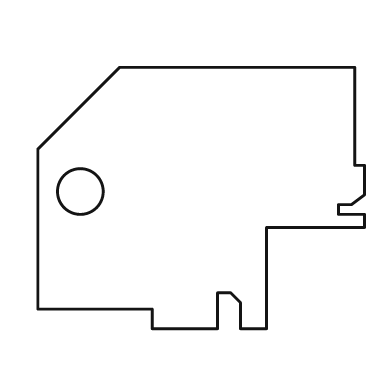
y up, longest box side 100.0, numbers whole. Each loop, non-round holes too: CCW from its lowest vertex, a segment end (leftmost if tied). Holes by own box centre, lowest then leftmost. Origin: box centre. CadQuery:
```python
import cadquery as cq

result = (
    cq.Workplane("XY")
    .moveTo(-15.0, -40.0)
    .lineTo(5.0, -40.0)
    .lineTo(5.0, -29.0)
    .lineTo(9.0, -29.0)
    .lineTo(12.0, -32.0)
    .lineTo(12.0, -40.0)
    .lineTo(20.0, -40.0)
    .lineTo(20.0, -9.0)
    .lineTo(50.0, -9.0)
    .lineTo(50.0, -5.0)
    .lineTo(42.0, -5.0)
    .lineTo(42.0, -2.0)
    .lineTo(46.0, -2.0)
    .lineTo(50.0, 1.0)
    .lineTo(50.0, 10.0)
    .lineTo(47.0, 10.0)
    .lineTo(47.0, 40.0)
    .lineTo(-25.0, 40.0)
    .lineTo(-50.0, 15.0)
    .lineTo(-50.0, -34.0)
    .lineTo(-15.0, -34.0)
    .close()
    .moveTo(-37.0, 2.0)
    .circle(7.0)
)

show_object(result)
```